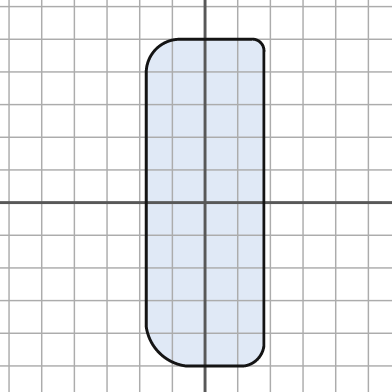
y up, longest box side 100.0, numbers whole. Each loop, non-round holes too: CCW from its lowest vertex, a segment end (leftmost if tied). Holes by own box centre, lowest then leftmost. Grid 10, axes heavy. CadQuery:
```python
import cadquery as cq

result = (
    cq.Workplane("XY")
    .moveTo(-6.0, -50.0)
    .lineTo(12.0, -50.0)
    .threePointArc((16.0, -48.0), (18.0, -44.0))
    .lineTo(18.0, 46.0)
    .threePointArc((17.0, 49.0), (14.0, 50.0))
    .lineTo(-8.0, 50.0)
    .threePointArc((-15.0, 47.0), (-18.0, 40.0))
    .lineTo(-18.0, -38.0)
    .threePointArc((-14.0, -46.0), (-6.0, -50.0))
    .close()
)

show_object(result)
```